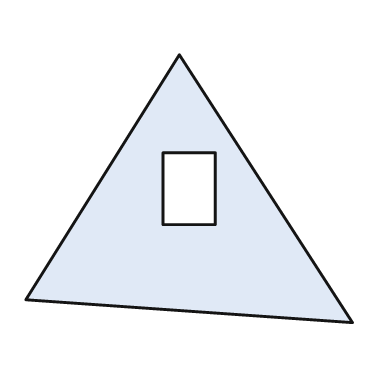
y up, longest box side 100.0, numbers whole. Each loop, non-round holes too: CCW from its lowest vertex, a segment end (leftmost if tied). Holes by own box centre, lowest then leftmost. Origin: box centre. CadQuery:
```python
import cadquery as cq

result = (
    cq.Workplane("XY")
    .moveTo(50.0, -41.0)
    .lineTo(-3.0, 41.0)
    .lineTo(-50.0, -34.0)
    .close()
    .moveTo(-8.0, -11.0)
    .lineTo(8.0, -11.0)
    .lineTo(8.0, 11.0)
    .lineTo(-8.0, 11.0)
    .close()
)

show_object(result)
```